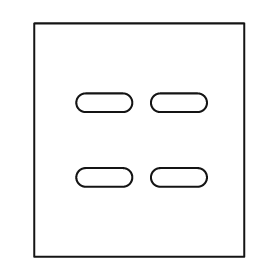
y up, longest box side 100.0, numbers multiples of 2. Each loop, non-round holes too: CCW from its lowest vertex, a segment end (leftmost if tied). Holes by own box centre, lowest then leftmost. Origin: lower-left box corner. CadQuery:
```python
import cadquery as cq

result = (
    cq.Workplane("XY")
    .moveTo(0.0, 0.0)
    .lineTo(90.0, 0.0)
    .lineTo(90.0, 100.0)
    .lineTo(0.0, 100.0)
    .close()
    .moveTo(22.0, 30.0)
    .lineTo(38.0, 30.0)
    .threePointArc((42.0, 34.0), (38.0, 38.0))
    .lineTo(22.0, 38.0)
    .threePointArc((18.0, 34.0), (22.0, 30.0))
    .close()
    .moveTo(54.0, 30.0)
    .lineTo(70.0, 30.0)
    .threePointArc((74.0, 34.0), (70.0, 38.0))
    .lineTo(54.0, 38.0)
    .threePointArc((50.0, 34.0), (54.0, 30.0))
    .close()
    .moveTo(22.0, 62.0)
    .lineTo(38.0, 62.0)
    .threePointArc((42.0, 66.0), (38.0, 70.0))
    .lineTo(22.0, 70.0)
    .threePointArc((18.0, 66.0), (22.0, 62.0))
    .close()
    .moveTo(54.0, 62.0)
    .lineTo(70.0, 62.0)
    .threePointArc((74.0, 66.0), (70.0, 70.0))
    .lineTo(54.0, 70.0)
    .threePointArc((50.0, 66.0), (54.0, 62.0))
    .close()
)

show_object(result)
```